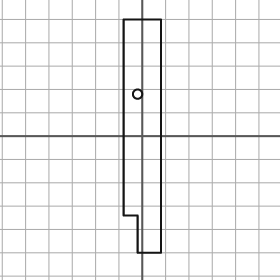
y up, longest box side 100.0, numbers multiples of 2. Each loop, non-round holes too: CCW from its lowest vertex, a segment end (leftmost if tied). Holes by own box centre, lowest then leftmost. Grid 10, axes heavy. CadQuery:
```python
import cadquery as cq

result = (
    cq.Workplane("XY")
    .moveTo(-2.0, -50.0)
    .lineTo(8.0, -50.0)
    .lineTo(8.0, 50.0)
    .lineTo(-8.0, 50.0)
    .lineTo(-8.0, -34.0)
    .lineTo(-2.0, -34.0)
    .close()
    .moveTo(-2.0, 18.0)
    .circle(2.0)
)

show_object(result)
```